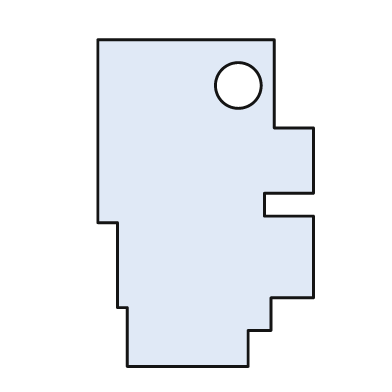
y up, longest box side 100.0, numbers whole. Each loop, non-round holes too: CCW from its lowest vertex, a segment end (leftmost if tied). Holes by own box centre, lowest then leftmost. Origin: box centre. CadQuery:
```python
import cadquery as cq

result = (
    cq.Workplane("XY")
    .moveTo(-24.0, -50.0)
    .lineTo(13.0, -50.0)
    .lineTo(13.0, -39.0)
    .lineTo(20.0, -39.0)
    .lineTo(20.0, -29.0)
    .lineTo(33.0, -29.0)
    .lineTo(33.0, -4.0)
    .lineTo(18.0, -4.0)
    .lineTo(18.0, 3.0)
    .lineTo(33.0, 3.0)
    .lineTo(33.0, 23.0)
    .lineTo(21.0, 23.0)
    .lineTo(21.0, 50.0)
    .lineTo(-33.0, 50.0)
    .lineTo(-33.0, -6.0)
    .lineTo(-27.0, -6.0)
    .lineTo(-27.0, -32.0)
    .lineTo(-24.0, -32.0)
    .close()
    .moveTo(10.0, 36.0)
    .circle(7.0)
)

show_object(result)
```